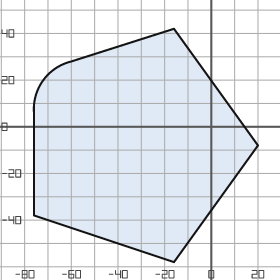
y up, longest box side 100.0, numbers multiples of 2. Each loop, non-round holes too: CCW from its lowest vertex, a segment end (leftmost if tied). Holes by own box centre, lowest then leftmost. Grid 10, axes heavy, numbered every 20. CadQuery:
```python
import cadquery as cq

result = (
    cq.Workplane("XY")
    .moveTo(-16.0, -58.0)
    .lineTo(20.0, -8.0)
    .lineTo(-16.0, 42.0)
    .lineTo(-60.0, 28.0)
    .threePointArc((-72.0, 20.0), (-76.0, 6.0))
    .lineTo(-76.0, -38.0)
    .close()
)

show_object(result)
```